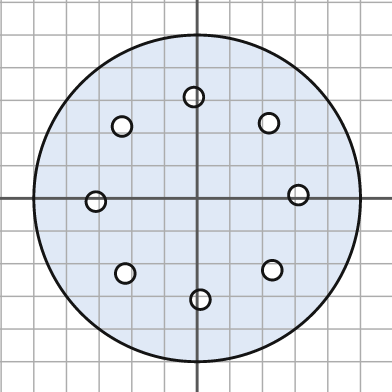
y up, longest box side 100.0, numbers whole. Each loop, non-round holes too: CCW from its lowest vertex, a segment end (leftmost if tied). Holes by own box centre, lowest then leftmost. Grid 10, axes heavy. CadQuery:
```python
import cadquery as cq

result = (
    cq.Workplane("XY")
    .moveTo(0.0, 0.0)
    .circle(50.0)
    .moveTo(1.0, -31.0)
    .circle(3.0)
    .moveTo(-22.0, -23.0)
    .circle(3.0)
    .moveTo(23.0, -22.0)
    .circle(3.0)
    .moveTo(-31.0, -1.0)
    .circle(3.0)
    .moveTo(31.0, 1.0)
    .circle(3.0)
    .moveTo(-23.0, 22.0)
    .circle(3.0)
    .moveTo(22.0, 23.0)
    .circle(3.0)
    .moveTo(-1.0, 31.0)
    .circle(3.0)
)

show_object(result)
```